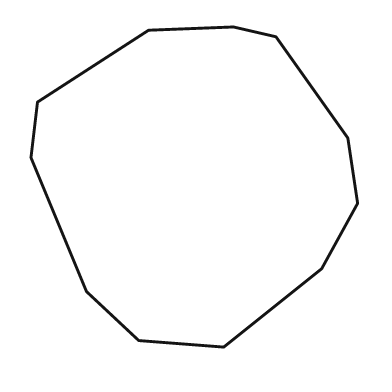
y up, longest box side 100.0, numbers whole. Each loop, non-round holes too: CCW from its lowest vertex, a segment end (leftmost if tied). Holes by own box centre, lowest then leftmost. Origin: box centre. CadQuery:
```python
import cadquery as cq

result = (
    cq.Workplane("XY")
    .moveTo(9.0, -49.0)
    .lineTo(39.0, -25.0)
    .lineTo(50.0, -5.0)
    .lineTo(47.0, 15.0)
    .lineTo(25.0, 46.0)
    .lineTo(12.0, 49.0)
    .lineTo(-14.0, 48.0)
    .lineTo(-48.0, 26.0)
    .lineTo(-50.0, 9.0)
    .lineTo(-33.0, -32.0)
    .lineTo(-17.0, -47.0)
    .close()
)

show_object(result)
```